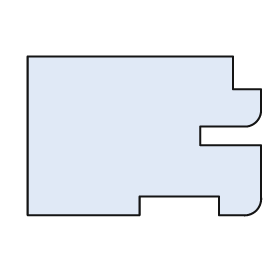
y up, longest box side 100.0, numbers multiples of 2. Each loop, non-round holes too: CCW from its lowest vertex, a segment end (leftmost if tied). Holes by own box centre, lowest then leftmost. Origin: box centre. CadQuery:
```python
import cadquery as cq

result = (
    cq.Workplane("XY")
    .moveTo(-50.0, -34.0)
    .lineTo(-2.0, -34.0)
    .lineTo(-2.0, -26.0)
    .lineTo(32.0, -26.0)
    .lineTo(32.0, -34.0)
    .lineTo(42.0, -34.0)
    .threePointArc((48.0, -32.0), (50.0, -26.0))
    .lineTo(50.0, -4.0)
    .lineTo(24.0, -4.0)
    .lineTo(24.0, 4.0)
    .lineTo(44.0, 4.0)
    .threePointArc((48.0, 6.0), (50.0, 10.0))
    .lineTo(50.0, 20.0)
    .lineTo(38.0, 20.0)
    .lineTo(38.0, 34.0)
    .lineTo(-50.0, 34.0)
    .close()
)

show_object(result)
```